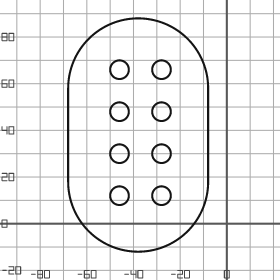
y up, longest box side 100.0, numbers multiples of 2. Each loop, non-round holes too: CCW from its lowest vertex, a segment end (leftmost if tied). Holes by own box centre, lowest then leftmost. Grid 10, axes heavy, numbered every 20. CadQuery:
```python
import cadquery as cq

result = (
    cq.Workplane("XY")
    .moveTo(-68.0, 18.0)
    .threePointArc((-38.0, -12.0), (-8.0, 18.0))
    .lineTo(-8.0, 58.0)
    .threePointArc((-38.0, 88.0), (-68.0, 58.0))
    .close()
    .moveTo(-46.0, 12.0)
    .circle(4.0)
    .moveTo(-28.0, 12.0)
    .circle(4.0)
    .moveTo(-46.0, 30.0)
    .circle(4.0)
    .moveTo(-28.0, 30.0)
    .circle(4.0)
    .moveTo(-46.0, 48.0)
    .circle(4.0)
    .moveTo(-28.0, 48.0)
    .circle(4.0)
    .moveTo(-46.0, 66.0)
    .circle(4.0)
    .moveTo(-28.0, 66.0)
    .circle(4.0)
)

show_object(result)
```